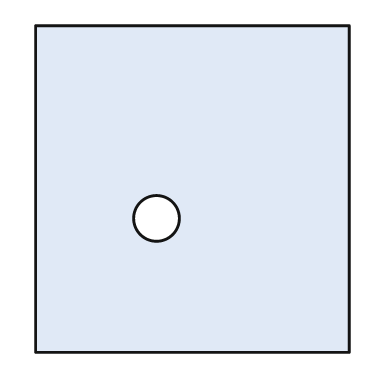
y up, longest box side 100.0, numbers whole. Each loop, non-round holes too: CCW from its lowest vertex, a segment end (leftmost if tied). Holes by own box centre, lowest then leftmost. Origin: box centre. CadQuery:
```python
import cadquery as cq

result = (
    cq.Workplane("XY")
    .moveTo(-48.0, -50.0)
    .lineTo(48.0, -50.0)
    .lineTo(48.0, 50.0)
    .lineTo(-48.0, 50.0)
    .close()
    .moveTo(-11.0, -9.0)
    .circle(7.0)
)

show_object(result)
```